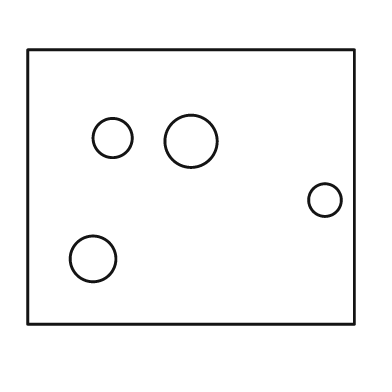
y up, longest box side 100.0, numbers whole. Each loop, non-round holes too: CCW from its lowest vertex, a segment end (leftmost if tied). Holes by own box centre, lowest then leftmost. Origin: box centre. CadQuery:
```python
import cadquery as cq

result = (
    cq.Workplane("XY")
    .moveTo(-50.0, -42.0)
    .lineTo(50.0, -42.0)
    .lineTo(50.0, 42.0)
    .lineTo(-50.0, 42.0)
    .close()
    .moveTo(-30.0, -22.0)
    .circle(7.0)
    .moveTo(41.0, -4.0)
    .circle(5.0)
    .moveTo(0.0, 14.0)
    .circle(8.0)
    .moveTo(-24.0, 15.0)
    .circle(6.0)
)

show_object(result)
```